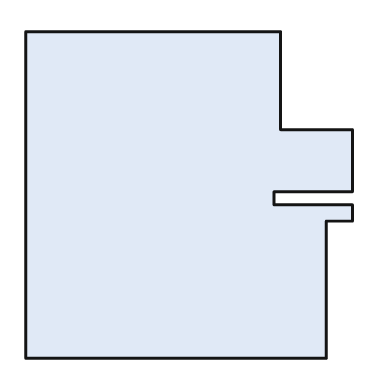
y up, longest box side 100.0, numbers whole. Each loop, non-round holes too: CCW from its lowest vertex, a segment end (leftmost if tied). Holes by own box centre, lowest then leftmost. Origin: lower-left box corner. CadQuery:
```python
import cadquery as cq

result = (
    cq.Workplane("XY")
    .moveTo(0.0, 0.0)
    .lineTo(92.0, 0.0)
    .lineTo(92.0, 42.0)
    .lineTo(100.0, 42.0)
    .lineTo(100.0, 47.0)
    .lineTo(76.0, 47.0)
    .lineTo(76.0, 51.0)
    .lineTo(100.0, 51.0)
    .lineTo(100.0, 70.0)
    .lineTo(78.0, 70.0)
    .lineTo(78.0, 100.0)
    .lineTo(0.0, 100.0)
    .close()
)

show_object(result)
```